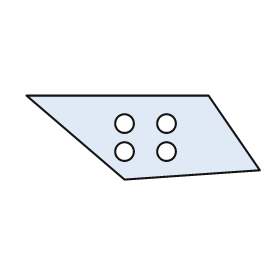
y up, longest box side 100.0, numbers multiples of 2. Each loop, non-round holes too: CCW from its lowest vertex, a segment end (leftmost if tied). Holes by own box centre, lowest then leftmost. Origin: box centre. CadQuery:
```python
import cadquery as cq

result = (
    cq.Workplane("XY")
    .moveTo(-8.0, -18.0)
    .lineTo(50.0, -14.0)
    .lineTo(28.0, 18.0)
    .lineTo(-50.0, 18.0)
    .close()
    .moveTo(-8.0, -6.0)
    .circle(4.0)
    .moveTo(10.0, -6.0)
    .circle(4.0)
    .moveTo(-8.0, 6.0)
    .circle(4.0)
    .moveTo(10.0, 6.0)
    .circle(4.0)
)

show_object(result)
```